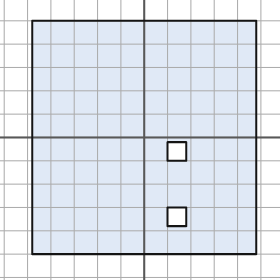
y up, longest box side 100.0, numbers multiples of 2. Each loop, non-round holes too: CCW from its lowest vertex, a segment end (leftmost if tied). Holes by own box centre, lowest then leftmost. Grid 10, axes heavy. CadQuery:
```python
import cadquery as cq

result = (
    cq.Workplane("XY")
    .moveTo(-48.0, -50.0)
    .lineTo(48.0, -50.0)
    .lineTo(48.0, 50.0)
    .lineTo(-48.0, 50.0)
    .close()
    .moveTo(10.0, -38.0)
    .lineTo(18.0, -38.0)
    .lineTo(18.0, -30.0)
    .lineTo(10.0, -30.0)
    .close()
    .moveTo(10.0, -10.0)
    .lineTo(18.0, -10.0)
    .lineTo(18.0, -2.0)
    .lineTo(10.0, -2.0)
    .close()
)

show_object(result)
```